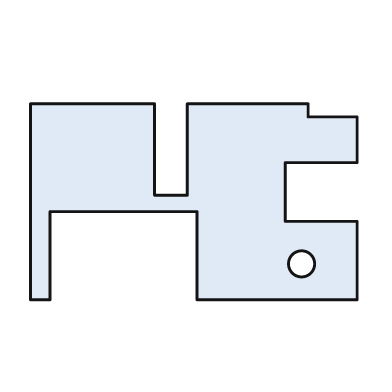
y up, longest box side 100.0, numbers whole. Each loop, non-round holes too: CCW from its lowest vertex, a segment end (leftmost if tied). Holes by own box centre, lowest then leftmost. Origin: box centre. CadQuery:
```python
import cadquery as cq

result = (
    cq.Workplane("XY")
    .moveTo(-50.0, -30.0)
    .lineTo(-44.0, -30.0)
    .lineTo(-44.0, -3.0)
    .lineTo(1.0, -3.0)
    .lineTo(1.0, -30.0)
    .lineTo(50.0, -30.0)
    .lineTo(50.0, -6.0)
    .lineTo(28.0, -6.0)
    .lineTo(28.0, 12.0)
    .lineTo(50.0, 12.0)
    .lineTo(50.0, 26.0)
    .lineTo(35.0, 26.0)
    .lineTo(35.0, 30.0)
    .lineTo(-2.0, 30.0)
    .lineTo(-2.0, 2.0)
    .lineTo(-12.0, 2.0)
    .lineTo(-12.0, 30.0)
    .lineTo(-50.0, 30.0)
    .close()
    .moveTo(33.0, -19.0)
    .circle(4.0)
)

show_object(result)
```